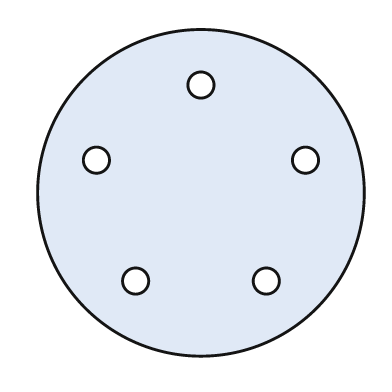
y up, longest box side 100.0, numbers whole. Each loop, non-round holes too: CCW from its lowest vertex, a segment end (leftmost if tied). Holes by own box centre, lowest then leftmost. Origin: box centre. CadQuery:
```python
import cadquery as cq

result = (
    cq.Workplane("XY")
    .moveTo(0.0, 0.0)
    .circle(50.0)
    .moveTo(-20.0, -27.0)
    .circle(4.0)
    .moveTo(20.0, -27.0)
    .circle(4.0)
    .moveTo(-32.0, 10.0)
    .circle(4.0)
    .moveTo(32.0, 10.0)
    .circle(4.0)
    .moveTo(0.0, 33.0)
    .circle(4.0)
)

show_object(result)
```